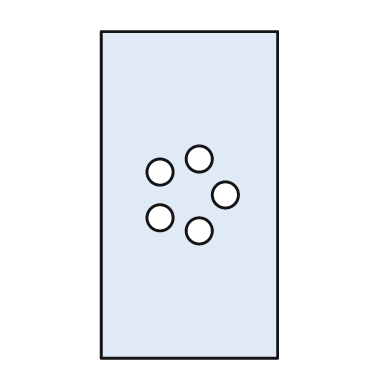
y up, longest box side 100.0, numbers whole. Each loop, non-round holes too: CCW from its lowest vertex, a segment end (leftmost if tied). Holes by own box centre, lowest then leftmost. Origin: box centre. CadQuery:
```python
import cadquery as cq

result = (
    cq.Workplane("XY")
    .moveTo(-27.0, -50.0)
    .lineTo(27.0, -50.0)
    .lineTo(27.0, 50.0)
    .lineTo(-27.0, 50.0)
    .close()
    .moveTo(3.0, -11.0)
    .circle(4.0)
    .moveTo(-9.0, -7.0)
    .circle(4.0)
    .moveTo(11.0, 0.0)
    .circle(4.0)
    .moveTo(-9.0, 7.0)
    .circle(4.0)
    .moveTo(3.0, 11.0)
    .circle(4.0)
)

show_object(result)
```